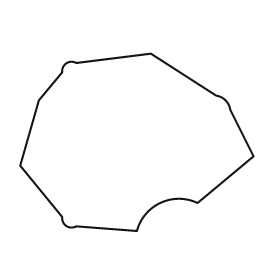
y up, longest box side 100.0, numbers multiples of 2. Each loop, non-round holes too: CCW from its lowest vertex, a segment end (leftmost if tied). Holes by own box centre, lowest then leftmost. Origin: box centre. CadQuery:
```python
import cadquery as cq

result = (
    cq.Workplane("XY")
    .moveTo(0.0, -38.0)
    .threePointArc((10.0, -26.0), (26.0, -26.0))
    .lineTo(50.0, -6.0)
    .lineTo(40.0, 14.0)
    .threePointArc((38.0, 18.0), (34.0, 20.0))
    .lineTo(6.0, 38.0)
    .lineTo(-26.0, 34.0)
    .threePointArc((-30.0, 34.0), (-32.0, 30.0))
    .lineTo(-42.0, 18.0)
    .lineTo(-50.0, -10.0)
    .lineTo(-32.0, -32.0)
    .threePointArc((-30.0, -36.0), (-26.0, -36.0))
    .close()
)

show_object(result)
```